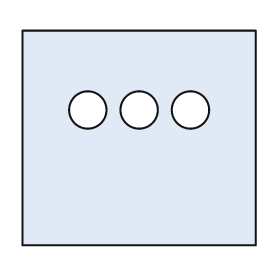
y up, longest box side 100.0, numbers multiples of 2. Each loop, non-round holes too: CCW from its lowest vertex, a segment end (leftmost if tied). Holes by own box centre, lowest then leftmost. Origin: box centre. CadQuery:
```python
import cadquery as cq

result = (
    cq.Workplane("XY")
    .moveTo(-50.0, -46.0)
    .lineTo(50.0, -46.0)
    .lineTo(50.0, 46.0)
    .lineTo(-50.0, 46.0)
    .close()
    .moveTo(-22.0, 12.0)
    .circle(8.0)
    .moveTo(0.0, 12.0)
    .circle(8.0)
    .moveTo(22.0, 12.0)
    .circle(8.0)
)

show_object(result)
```